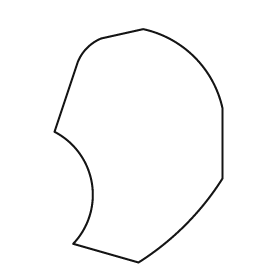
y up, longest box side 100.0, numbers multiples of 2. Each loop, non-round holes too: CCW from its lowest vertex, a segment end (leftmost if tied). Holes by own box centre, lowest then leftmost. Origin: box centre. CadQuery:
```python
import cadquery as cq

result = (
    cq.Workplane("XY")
    .moveTo(0.0, -50.0)
    .threePointArc((20.0, -34.0), (36.0, -14.0))
    .lineTo(36.0, 16.0)
    .threePointArc((24.0, 38.0), (2.0, 50.0))
    .lineTo(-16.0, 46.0)
    .threePointArc((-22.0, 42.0), (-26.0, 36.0))
    .lineTo(-36.0, 6.0)
    .threePointArc((-20.0, -16.0), (-28.0, -42.0))
    .close()
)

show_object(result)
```